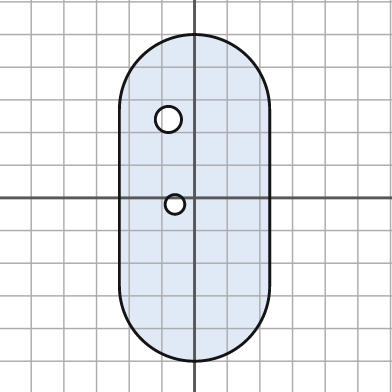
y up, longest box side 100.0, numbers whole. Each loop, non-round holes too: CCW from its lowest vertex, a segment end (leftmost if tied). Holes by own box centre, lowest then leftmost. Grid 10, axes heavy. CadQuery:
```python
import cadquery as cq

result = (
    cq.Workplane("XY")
    .moveTo(-23.0, -27.0)
    .threePointArc((0.0, -50.0), (23.0, -27.0))
    .lineTo(23.0, 27.0)
    .threePointArc((0.0, 50.0), (-23.0, 27.0))
    .close()
    .moveTo(-6.0, -2.0)
    .circle(3.0)
    .moveTo(-8.0, 24.0)
    .circle(4.0)
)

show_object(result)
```